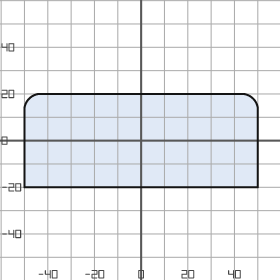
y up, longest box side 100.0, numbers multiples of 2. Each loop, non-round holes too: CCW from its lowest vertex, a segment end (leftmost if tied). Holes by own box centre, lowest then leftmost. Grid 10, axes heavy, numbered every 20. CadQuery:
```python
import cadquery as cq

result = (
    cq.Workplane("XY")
    .moveTo(-50.0, -20.0)
    .lineTo(50.0, -20.0)
    .lineTo(50.0, 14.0)
    .threePointArc((48.0, 18.0), (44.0, 20.0))
    .lineTo(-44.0, 20.0)
    .threePointArc((-48.0, 18.0), (-50.0, 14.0))
    .close()
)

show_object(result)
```